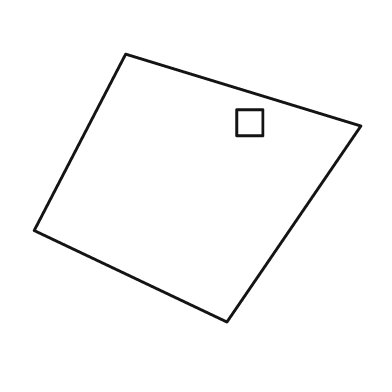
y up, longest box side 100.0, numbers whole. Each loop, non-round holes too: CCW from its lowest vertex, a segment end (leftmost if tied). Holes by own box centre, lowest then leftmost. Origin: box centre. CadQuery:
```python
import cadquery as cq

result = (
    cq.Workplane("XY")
    .moveTo(9.0, -41.0)
    .lineTo(50.0, 19.0)
    .lineTo(-22.0, 41.0)
    .lineTo(-50.0, -13.0)
    .close()
    .moveTo(12.0, 16.0)
    .lineTo(20.0, 16.0)
    .lineTo(20.0, 24.0)
    .lineTo(12.0, 24.0)
    .close()
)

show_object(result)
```